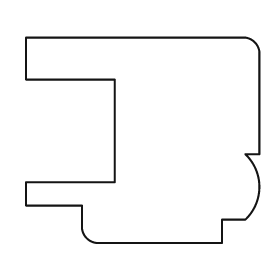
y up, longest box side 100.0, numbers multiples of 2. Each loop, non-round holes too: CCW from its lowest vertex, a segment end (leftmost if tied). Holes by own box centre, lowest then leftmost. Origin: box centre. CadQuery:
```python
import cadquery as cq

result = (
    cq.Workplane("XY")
    .moveTo(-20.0, -44.0)
    .lineTo(34.0, -44.0)
    .lineTo(34.0, -34.0)
    .lineTo(44.0, -34.0)
    .threePointArc((50.0, -20.0), (44.0, -6.0))
    .lineTo(50.0, -6.0)
    .lineTo(50.0, 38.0)
    .threePointArc((48.0, 42.0), (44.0, 44.0))
    .lineTo(-50.0, 44.0)
    .lineTo(-50.0, 26.0)
    .lineTo(-12.0, 26.0)
    .lineTo(-12.0, -18.0)
    .lineTo(-50.0, -18.0)
    .lineTo(-50.0, -28.0)
    .lineTo(-26.0, -28.0)
    .lineTo(-26.0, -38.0)
    .threePointArc((-24.0, -42.0), (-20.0, -44.0))
    .close()
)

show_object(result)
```